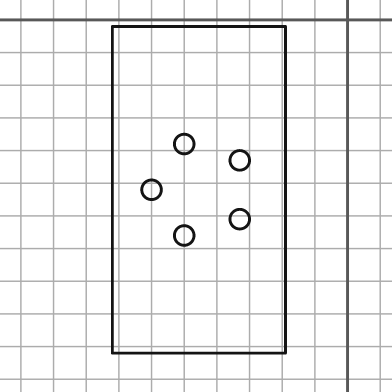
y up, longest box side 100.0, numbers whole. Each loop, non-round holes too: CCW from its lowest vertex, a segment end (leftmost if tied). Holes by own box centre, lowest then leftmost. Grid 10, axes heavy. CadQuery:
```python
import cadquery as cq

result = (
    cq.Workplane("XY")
    .moveTo(-72.0, -102.0)
    .lineTo(-19.0, -102.0)
    .lineTo(-19.0, -2.0)
    .lineTo(-72.0, -2.0)
    .close()
    .moveTo(-50.0, -66.0)
    .circle(3.0)
    .moveTo(-33.0, -61.0)
    .circle(3.0)
    .moveTo(-60.0, -52.0)
    .circle(3.0)
    .moveTo(-33.0, -43.0)
    .circle(3.0)
    .moveTo(-50.0, -38.0)
    .circle(3.0)
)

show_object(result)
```